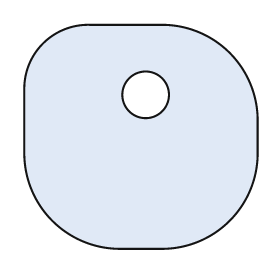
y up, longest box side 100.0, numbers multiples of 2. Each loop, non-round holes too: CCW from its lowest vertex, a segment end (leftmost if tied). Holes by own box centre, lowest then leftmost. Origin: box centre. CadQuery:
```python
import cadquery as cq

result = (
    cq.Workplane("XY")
    .moveTo(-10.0, -48.0)
    .lineTo(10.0, -48.0)
    .threePointArc((38.0, -36.0), (50.0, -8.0))
    .lineTo(50.0, 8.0)
    .threePointArc((38.0, 36.0), (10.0, 48.0))
    .lineTo(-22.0, 48.0)
    .threePointArc((-42.0, 40.0), (-50.0, 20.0))
    .lineTo(-50.0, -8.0)
    .threePointArc((-38.0, -36.0), (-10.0, -48.0))
    .close()
    .moveTo(2.0, 18.0)
    .circle(10.0)
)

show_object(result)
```